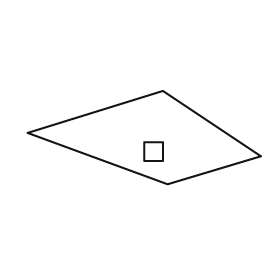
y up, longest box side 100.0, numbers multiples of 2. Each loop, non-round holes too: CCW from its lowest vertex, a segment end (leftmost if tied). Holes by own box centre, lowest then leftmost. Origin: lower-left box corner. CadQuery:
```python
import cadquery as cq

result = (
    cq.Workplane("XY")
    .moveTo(60.0, 0.0)
    .lineTo(100.0, 12.0)
    .lineTo(58.0, 40.0)
    .lineTo(0.0, 22.0)
    .close()
    .moveTo(50.0, 10.0)
    .lineTo(58.0, 10.0)
    .lineTo(58.0, 18.0)
    .lineTo(50.0, 18.0)
    .close()
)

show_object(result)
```